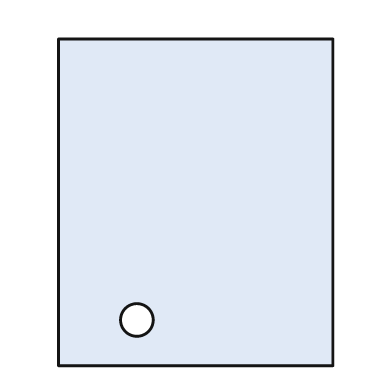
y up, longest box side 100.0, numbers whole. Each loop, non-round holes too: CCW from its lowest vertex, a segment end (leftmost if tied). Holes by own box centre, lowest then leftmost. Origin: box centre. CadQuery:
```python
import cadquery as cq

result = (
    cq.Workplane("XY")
    .moveTo(-42.0, -50.0)
    .lineTo(42.0, -50.0)
    .lineTo(42.0, 50.0)
    .lineTo(-42.0, 50.0)
    .close()
    .moveTo(-18.0, -36.0)
    .circle(5.0)
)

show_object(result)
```